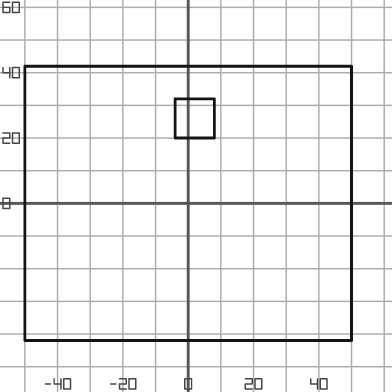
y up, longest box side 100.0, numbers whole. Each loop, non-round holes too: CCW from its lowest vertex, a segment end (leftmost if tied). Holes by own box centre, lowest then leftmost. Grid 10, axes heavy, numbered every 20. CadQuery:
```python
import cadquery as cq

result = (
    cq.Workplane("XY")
    .moveTo(-50.0, -42.0)
    .lineTo(50.0, -42.0)
    .lineTo(50.0, 42.0)
    .lineTo(-50.0, 42.0)
    .close()
    .moveTo(-4.0, 20.0)
    .lineTo(8.0, 20.0)
    .lineTo(8.0, 32.0)
    .lineTo(-4.0, 32.0)
    .close()
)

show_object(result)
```